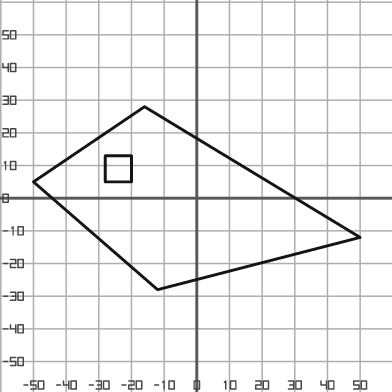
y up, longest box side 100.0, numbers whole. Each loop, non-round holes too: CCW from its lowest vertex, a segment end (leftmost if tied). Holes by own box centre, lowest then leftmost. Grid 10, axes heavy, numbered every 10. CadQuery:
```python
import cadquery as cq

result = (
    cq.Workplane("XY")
    .moveTo(-12.0, -28.0)
    .lineTo(50.0, -12.0)
    .lineTo(-16.0, 28.0)
    .lineTo(-50.0, 5.0)
    .close()
    .moveTo(-28.0, 5.0)
    .lineTo(-20.0, 5.0)
    .lineTo(-20.0, 13.0)
    .lineTo(-28.0, 13.0)
    .close()
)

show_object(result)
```